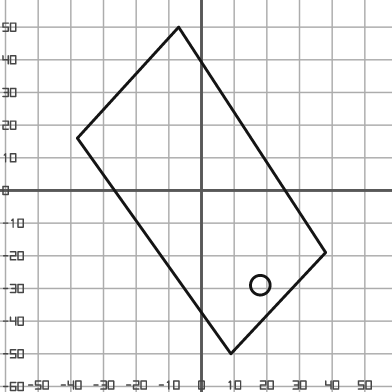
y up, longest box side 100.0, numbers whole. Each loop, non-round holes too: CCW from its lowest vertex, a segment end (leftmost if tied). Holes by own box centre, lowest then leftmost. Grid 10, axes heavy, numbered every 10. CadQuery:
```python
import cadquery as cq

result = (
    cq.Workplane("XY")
    .moveTo(9.0, -50.0)
    .lineTo(38.0, -19.0)
    .lineTo(-7.0, 50.0)
    .lineTo(-38.0, 16.0)
    .close()
    .moveTo(18.0, -29.0)
    .circle(3.0)
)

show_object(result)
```